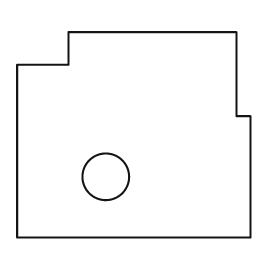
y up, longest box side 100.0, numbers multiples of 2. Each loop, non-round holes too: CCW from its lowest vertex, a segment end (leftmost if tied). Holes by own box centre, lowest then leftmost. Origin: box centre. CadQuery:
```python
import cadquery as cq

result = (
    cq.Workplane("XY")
    .moveTo(-50.0, -44.0)
    .lineTo(50.0, -44.0)
    .lineTo(50.0, 8.0)
    .lineTo(44.0, 8.0)
    .lineTo(44.0, 44.0)
    .lineTo(-28.0, 44.0)
    .lineTo(-28.0, 30.0)
    .lineTo(-50.0, 30.0)
    .close()
    .moveTo(-12.0, -18.0)
    .circle(10.0)
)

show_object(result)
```